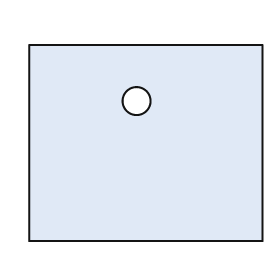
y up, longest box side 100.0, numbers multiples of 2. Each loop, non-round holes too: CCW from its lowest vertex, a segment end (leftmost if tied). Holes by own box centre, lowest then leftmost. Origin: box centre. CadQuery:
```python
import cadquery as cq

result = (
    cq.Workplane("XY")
    .moveTo(-50.0, -42.0)
    .lineTo(50.0, -42.0)
    .lineTo(50.0, 42.0)
    .lineTo(-50.0, 42.0)
    .close()
    .moveTo(-4.0, 18.0)
    .circle(6.0)
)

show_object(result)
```